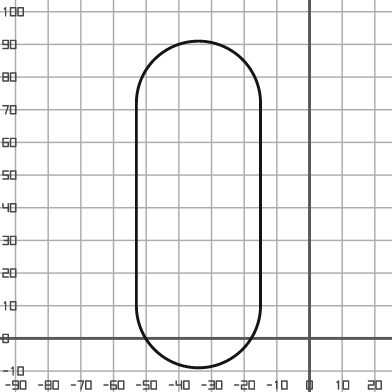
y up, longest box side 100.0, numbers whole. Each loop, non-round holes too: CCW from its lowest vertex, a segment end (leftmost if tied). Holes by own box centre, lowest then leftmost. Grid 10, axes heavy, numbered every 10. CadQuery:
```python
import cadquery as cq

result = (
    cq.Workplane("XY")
    .moveTo(-53.0, 10.0)
    .threePointArc((-34.0, -9.0), (-15.0, 10.0))
    .lineTo(-15.0, 72.0)
    .threePointArc((-34.0, 91.0), (-53.0, 72.0))
    .close()
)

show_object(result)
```